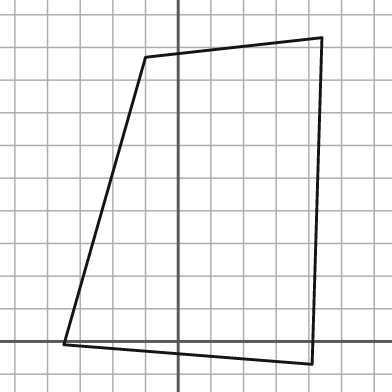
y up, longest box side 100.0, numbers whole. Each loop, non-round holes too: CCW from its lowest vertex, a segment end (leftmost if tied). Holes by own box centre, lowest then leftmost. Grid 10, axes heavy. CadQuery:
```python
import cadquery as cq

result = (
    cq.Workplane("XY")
    .moveTo(41.0, -7.0)
    .lineTo(44.0, 93.0)
    .lineTo(-10.0, 87.0)
    .lineTo(-35.0, -1.0)
    .close()
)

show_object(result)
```